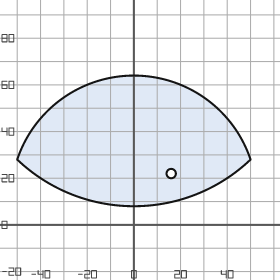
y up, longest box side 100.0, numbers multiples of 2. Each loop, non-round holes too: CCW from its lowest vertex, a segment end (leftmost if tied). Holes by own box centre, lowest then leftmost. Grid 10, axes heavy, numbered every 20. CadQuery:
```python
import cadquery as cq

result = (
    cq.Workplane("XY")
    .moveTo(-50.0, 28.0)
    .threePointArc((0.0, 8.0), (50.0, 28.0))
    .threePointArc((0.0, 64.0), (-50.0, 28.0))
    .close()
    .moveTo(16.0, 22.0)
    .circle(2.0)
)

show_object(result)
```